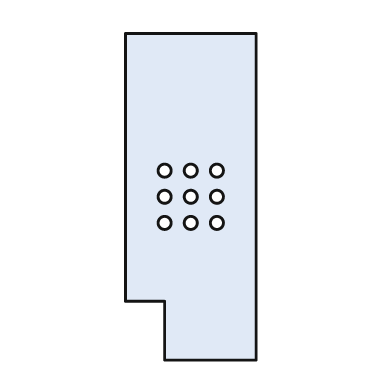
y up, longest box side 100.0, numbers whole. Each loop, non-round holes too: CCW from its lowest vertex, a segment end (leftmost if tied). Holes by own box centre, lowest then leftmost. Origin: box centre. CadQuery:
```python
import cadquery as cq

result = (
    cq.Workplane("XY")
    .moveTo(-8.0, -50.0)
    .lineTo(20.0, -50.0)
    .lineTo(20.0, 50.0)
    .lineTo(-20.0, 50.0)
    .lineTo(-20.0, -32.0)
    .lineTo(-8.0, -32.0)
    .close()
    .moveTo(-8.0, -8.0)
    .circle(2.0)
    .moveTo(0.0, -8.0)
    .circle(2.0)
    .moveTo(8.0, -8.0)
    .circle(2.0)
    .moveTo(-8.0, 0.0)
    .circle(2.0)
    .moveTo(0.0, 0.0)
    .circle(2.0)
    .moveTo(8.0, 0.0)
    .circle(2.0)
    .moveTo(-8.0, 8.0)
    .circle(2.0)
    .moveTo(0.0, 8.0)
    .circle(2.0)
    .moveTo(8.0, 8.0)
    .circle(2.0)
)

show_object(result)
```